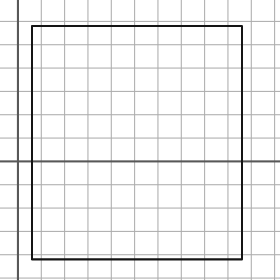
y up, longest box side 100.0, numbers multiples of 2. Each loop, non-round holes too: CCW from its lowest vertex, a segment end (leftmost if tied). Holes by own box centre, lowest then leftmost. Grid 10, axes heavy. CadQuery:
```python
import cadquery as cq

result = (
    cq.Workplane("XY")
    .moveTo(6.0, -42.0)
    .lineTo(96.0, -42.0)
    .lineTo(96.0, 58.0)
    .lineTo(6.0, 58.0)
    .close()
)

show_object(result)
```